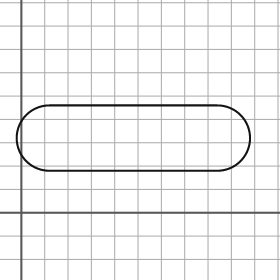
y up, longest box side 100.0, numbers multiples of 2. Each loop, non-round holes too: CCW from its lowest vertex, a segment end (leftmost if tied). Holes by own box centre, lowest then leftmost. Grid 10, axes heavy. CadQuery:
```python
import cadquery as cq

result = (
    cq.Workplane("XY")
    .moveTo(12.0, 18.0)
    .lineTo(84.0, 18.0)
    .threePointArc((98.0, 32.0), (84.0, 46.0))
    .lineTo(12.0, 46.0)
    .threePointArc((-2.0, 32.0), (12.0, 18.0))
    .close()
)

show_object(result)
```